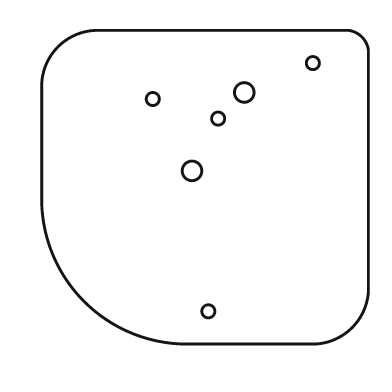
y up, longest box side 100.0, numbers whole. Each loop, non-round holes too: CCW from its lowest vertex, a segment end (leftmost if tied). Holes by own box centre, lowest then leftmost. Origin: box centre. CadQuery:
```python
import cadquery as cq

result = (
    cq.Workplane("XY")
    .moveTo(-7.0, -48.0)
    .lineTo(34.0, -48.0)
    .threePointArc((45.0, -43.0), (50.0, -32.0))
    .lineTo(50.0, 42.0)
    .threePointArc((48.0, 46.0), (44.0, 48.0))
    .lineTo(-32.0, 48.0)
    .threePointArc((-45.0, 43.0), (-50.0, 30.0))
    .lineTo(-50.0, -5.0)
    .threePointArc((-37.0, -35.0), (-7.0, -48.0))
    .close()
    .moveTo(1.0, -38.0)
    .circle(2.0)
    .moveTo(-4.0, 5.0)
    .circle(3.0)
    .moveTo(4.0, 21.0)
    .circle(2.0)
    .moveTo(-16.0, 27.0)
    .circle(2.0)
    .moveTo(12.0, 29.0)
    .circle(3.0)
    .moveTo(33.0, 38.0)
    .circle(2.0)
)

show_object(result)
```